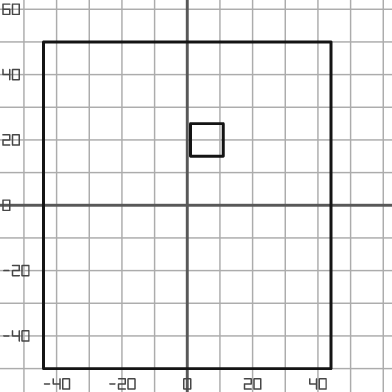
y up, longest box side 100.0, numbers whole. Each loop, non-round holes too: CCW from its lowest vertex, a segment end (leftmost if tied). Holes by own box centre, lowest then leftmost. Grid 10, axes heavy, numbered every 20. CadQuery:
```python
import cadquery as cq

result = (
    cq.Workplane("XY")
    .moveTo(-44.0, -50.0)
    .lineTo(44.0, -50.0)
    .lineTo(44.0, 50.0)
    .lineTo(-44.0, 50.0)
    .close()
    .moveTo(1.0, 15.0)
    .lineTo(11.0, 15.0)
    .lineTo(11.0, 25.0)
    .lineTo(1.0, 25.0)
    .close()
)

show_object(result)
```